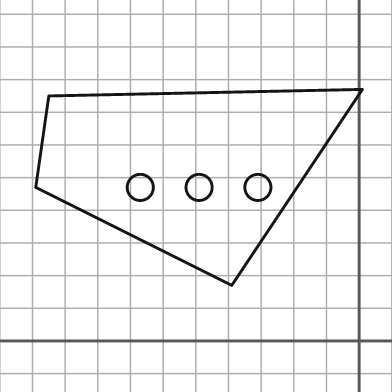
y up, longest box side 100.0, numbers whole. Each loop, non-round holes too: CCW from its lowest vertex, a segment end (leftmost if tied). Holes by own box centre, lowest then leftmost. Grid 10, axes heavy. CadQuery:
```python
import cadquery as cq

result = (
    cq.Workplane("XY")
    .moveTo(-39.0, 17.0)
    .lineTo(1.0, 77.0)
    .lineTo(-95.0, 75.0)
    .lineTo(-99.0, 47.0)
    .close()
    .moveTo(-67.0, 47.0)
    .circle(4.0)
    .moveTo(-49.0, 47.0)
    .circle(4.0)
    .moveTo(-31.0, 47.0)
    .circle(4.0)
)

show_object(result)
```